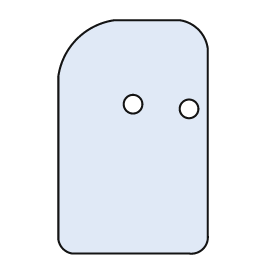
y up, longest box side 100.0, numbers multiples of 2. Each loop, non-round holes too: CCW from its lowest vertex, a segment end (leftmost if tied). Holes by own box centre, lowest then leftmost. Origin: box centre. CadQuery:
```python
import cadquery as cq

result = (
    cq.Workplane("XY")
    .moveTo(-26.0, -50.0)
    .lineTo(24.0, -50.0)
    .threePointArc((30.0, -48.0), (32.0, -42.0))
    .lineTo(32.0, 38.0)
    .threePointArc((28.0, 46.0), (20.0, 50.0))
    .lineTo(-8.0, 50.0)
    .threePointArc((-24.0, 42.0), (-32.0, 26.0))
    .lineTo(-32.0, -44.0)
    .threePointArc((-30.0, -48.0), (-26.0, -50.0))
    .close()
    .moveTo(24.0, 12.0)
    .circle(4.0)
    .moveTo(0.0, 14.0)
    .circle(4.0)
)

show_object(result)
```